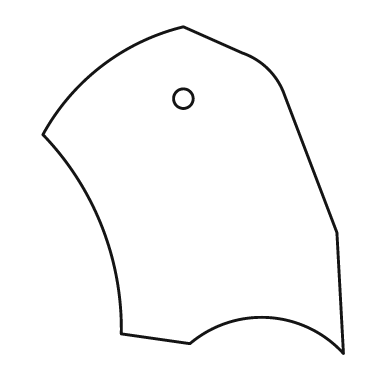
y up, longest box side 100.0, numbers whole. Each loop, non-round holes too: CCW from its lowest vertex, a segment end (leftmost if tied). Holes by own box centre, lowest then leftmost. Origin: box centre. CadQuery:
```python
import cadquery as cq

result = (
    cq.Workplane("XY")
    .moveTo(46.0, -50.0)
    .lineTo(44.0, -13.0)
    .lineTo(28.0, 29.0)
    .threePointArc((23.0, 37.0), (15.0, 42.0))
    .lineTo(-3.0, 50.0)
    .threePointArc((-28.0, 38.0), (-46.0, 17.0))
    .threePointArc((-28.0, -11.0), (-22.0, -44.0))
    .lineTo(-1.0, -47.0)
    .threePointArc((23.0, -39.0), (46.0, -50.0))
    .close()
    .moveTo(-3.0, 28.0)
    .circle(3.0)
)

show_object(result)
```